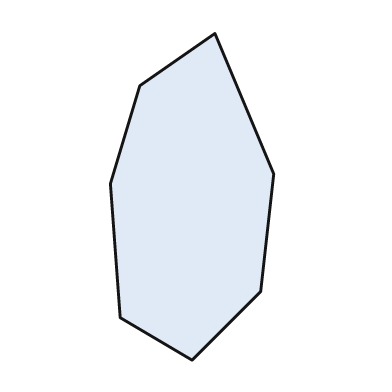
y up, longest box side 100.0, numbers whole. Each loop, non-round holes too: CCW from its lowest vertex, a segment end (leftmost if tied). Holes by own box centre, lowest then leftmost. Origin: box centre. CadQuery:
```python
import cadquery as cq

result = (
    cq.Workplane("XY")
    .moveTo(0.0, -50.0)
    .lineTo(21.0, -29.0)
    .lineTo(25.0, 7.0)
    .lineTo(7.0, 50.0)
    .lineTo(-16.0, 34.0)
    .lineTo(-25.0, 4.0)
    .lineTo(-22.0, -37.0)
    .close()
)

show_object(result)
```